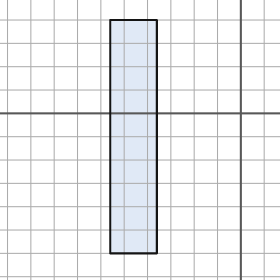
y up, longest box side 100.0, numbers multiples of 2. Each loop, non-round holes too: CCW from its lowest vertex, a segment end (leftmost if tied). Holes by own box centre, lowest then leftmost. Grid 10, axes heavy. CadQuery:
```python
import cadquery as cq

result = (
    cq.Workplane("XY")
    .moveTo(-56.0, -60.0)
    .lineTo(-36.0, -60.0)
    .lineTo(-36.0, 40.0)
    .lineTo(-56.0, 40.0)
    .close()
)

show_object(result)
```